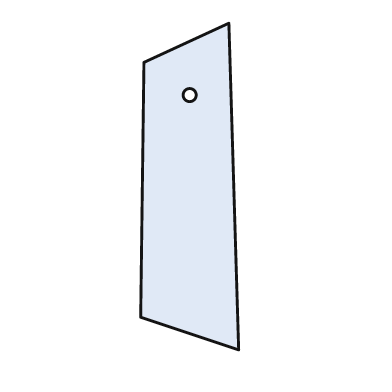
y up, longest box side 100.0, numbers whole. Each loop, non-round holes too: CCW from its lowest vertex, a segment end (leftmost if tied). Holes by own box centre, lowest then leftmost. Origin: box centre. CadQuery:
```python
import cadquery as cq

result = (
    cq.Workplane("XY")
    .moveTo(15.0, -50.0)
    .lineTo(12.0, 50.0)
    .lineTo(-14.0, 38.0)
    .lineTo(-15.0, -40.0)
    .close()
    .moveTo(0.0, 28.0)
    .circle(2.0)
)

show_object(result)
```